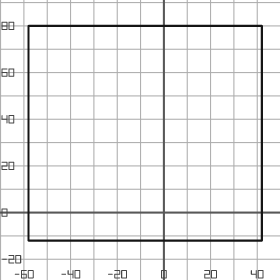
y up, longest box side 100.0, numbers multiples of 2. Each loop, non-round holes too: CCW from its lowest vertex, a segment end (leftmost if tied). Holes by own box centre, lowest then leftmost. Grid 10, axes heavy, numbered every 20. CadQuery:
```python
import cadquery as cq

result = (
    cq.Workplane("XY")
    .moveTo(-58.0, -12.0)
    .lineTo(42.0, -12.0)
    .lineTo(42.0, 80.0)
    .lineTo(-58.0, 80.0)
    .close()
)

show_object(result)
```